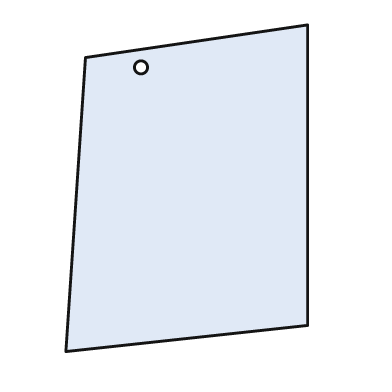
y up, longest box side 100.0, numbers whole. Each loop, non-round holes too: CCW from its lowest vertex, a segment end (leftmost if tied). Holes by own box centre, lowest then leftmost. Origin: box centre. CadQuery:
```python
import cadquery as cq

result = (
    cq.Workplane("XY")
    .moveTo(-37.0, -50.0)
    .lineTo(37.0, -42.0)
    .lineTo(37.0, 50.0)
    .lineTo(-31.0, 40.0)
    .close()
    .moveTo(-14.0, 37.0)
    .circle(2.0)
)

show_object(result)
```